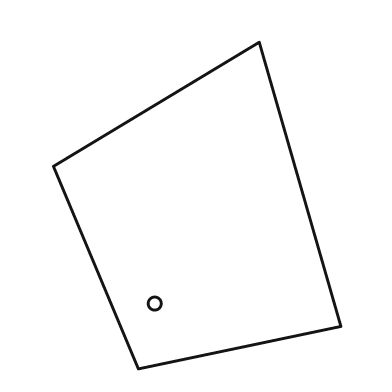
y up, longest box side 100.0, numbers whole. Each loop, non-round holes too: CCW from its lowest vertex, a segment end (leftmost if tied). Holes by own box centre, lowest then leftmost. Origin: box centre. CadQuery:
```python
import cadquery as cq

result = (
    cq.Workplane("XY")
    .moveTo(-18.0, -50.0)
    .lineTo(44.0, -37.0)
    .lineTo(19.0, 50.0)
    .lineTo(-44.0, 12.0)
    .close()
    .moveTo(-13.0, -30.0)
    .circle(2.0)
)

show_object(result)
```